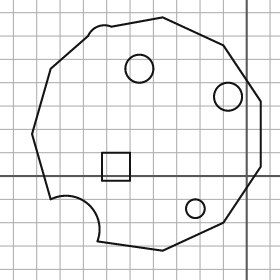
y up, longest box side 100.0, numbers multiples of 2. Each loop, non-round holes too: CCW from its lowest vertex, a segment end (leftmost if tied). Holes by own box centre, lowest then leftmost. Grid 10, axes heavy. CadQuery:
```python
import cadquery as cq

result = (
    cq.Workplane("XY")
    .moveTo(-36.0, -32.0)
    .lineTo(-10.0, -20.0)
    .lineTo(6.0, 4.0)
    .lineTo(6.0, 32.0)
    .lineTo(-10.0, 56.0)
    .lineTo(-36.0, 68.0)
    .lineTo(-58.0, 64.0)
    .threePointArc((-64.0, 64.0), (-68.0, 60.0))
    .lineTo(-84.0, 46.0)
    .lineTo(-92.0, 18.0)
    .lineTo(-84.0, -10.0)
    .threePointArc((-68.0, -12.0), (-64.0, -28.0))
    .close()
    .moveTo(-22.0, -14.0)
    .circle(4.0)
    .moveTo(-62.0, -2.0)
    .lineTo(-50.0, -2.0)
    .lineTo(-50.0, 10.0)
    .lineTo(-62.0, 10.0)
    .close()
    .moveTo(-8.0, 34.0)
    .circle(6.0)
    .moveTo(-46.0, 46.0)
    .circle(6.0)
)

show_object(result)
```